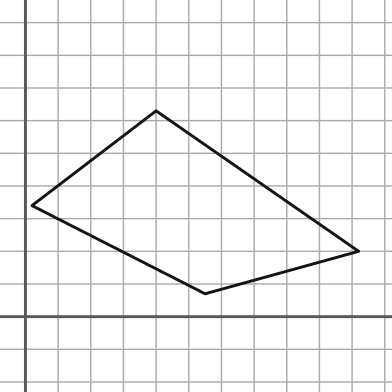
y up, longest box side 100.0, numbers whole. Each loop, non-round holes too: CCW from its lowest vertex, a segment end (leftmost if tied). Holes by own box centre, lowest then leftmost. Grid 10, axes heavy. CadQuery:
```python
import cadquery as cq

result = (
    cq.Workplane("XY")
    .moveTo(55.0, 7.0)
    .lineTo(102.0, 20.0)
    .lineTo(40.0, 63.0)
    .lineTo(2.0, 34.0)
    .close()
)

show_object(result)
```